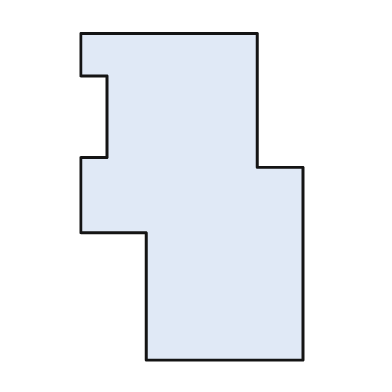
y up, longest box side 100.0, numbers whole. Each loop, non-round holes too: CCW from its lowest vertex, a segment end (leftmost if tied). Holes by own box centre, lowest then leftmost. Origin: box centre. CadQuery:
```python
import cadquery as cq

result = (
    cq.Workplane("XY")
    .moveTo(-14.0, -50.0)
    .lineTo(34.0, -50.0)
    .lineTo(34.0, 9.0)
    .lineTo(20.0, 9.0)
    .lineTo(20.0, 50.0)
    .lineTo(-34.0, 50.0)
    .lineTo(-34.0, 37.0)
    .lineTo(-26.0, 37.0)
    .lineTo(-26.0, 12.0)
    .lineTo(-34.0, 12.0)
    .lineTo(-34.0, -11.0)
    .lineTo(-14.0, -11.0)
    .close()
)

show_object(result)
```